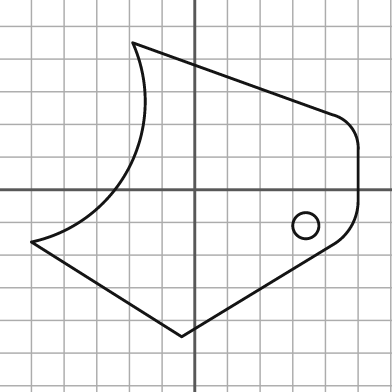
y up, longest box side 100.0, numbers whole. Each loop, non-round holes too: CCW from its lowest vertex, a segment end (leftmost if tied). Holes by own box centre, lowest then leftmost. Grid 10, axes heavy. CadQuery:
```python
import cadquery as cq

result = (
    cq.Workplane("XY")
    .moveTo(-4.0, -45.0)
    .lineTo(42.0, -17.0)
    .threePointArc((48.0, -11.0), (50.0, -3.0))
    .lineTo(50.0, 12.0)
    .threePointArc((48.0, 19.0), (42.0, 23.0))
    .lineTo(-19.0, 45.0)
    .threePointArc((-20.0, 7.0), (-50.0, -16.0))
    .close()
    .moveTo(34.0, -11.0)
    .circle(4.0)
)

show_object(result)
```